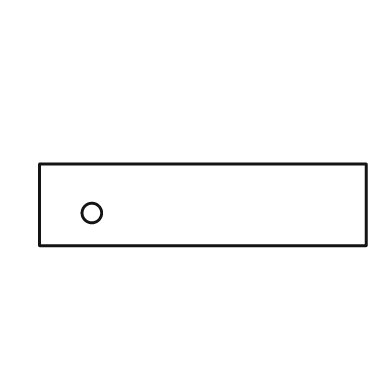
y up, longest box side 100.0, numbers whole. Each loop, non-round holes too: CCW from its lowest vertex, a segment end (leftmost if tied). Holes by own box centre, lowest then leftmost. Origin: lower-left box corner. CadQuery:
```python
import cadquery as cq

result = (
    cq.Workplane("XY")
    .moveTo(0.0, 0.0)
    .lineTo(100.0, 0.0)
    .lineTo(100.0, 25.0)
    .lineTo(0.0, 25.0)
    .close()
    .moveTo(16.0, 10.0)
    .circle(3.0)
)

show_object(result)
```